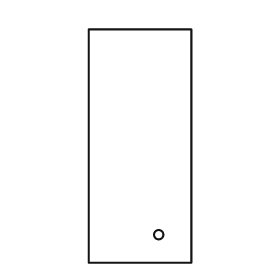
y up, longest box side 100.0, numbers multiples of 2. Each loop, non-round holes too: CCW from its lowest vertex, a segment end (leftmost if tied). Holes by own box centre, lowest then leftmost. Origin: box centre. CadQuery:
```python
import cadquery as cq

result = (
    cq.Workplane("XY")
    .moveTo(-22.0, -50.0)
    .lineTo(22.0, -50.0)
    .lineTo(22.0, 50.0)
    .lineTo(-22.0, 50.0)
    .close()
    .moveTo(8.0, -38.0)
    .circle(2.0)
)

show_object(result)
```